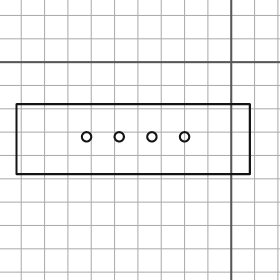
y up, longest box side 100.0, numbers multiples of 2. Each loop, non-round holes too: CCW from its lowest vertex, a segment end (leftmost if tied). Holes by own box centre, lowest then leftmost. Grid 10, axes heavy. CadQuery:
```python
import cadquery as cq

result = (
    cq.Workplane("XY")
    .moveTo(-92.0, -48.0)
    .lineTo(8.0, -48.0)
    .lineTo(8.0, -18.0)
    .lineTo(-92.0, -18.0)
    .close()
    .moveTo(-62.0, -32.0)
    .circle(2.0)
    .moveTo(-48.0, -32.0)
    .circle(2.0)
    .moveTo(-34.0, -32.0)
    .circle(2.0)
    .moveTo(-20.0, -32.0)
    .circle(2.0)
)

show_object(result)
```